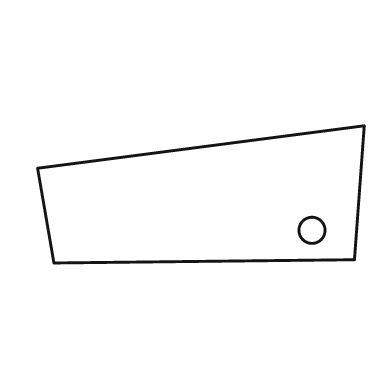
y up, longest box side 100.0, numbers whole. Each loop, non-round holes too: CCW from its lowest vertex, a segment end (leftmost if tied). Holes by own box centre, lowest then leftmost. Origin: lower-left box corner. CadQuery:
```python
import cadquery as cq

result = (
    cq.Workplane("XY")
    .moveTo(5.0, 0.0)
    .lineTo(97.0, 1.0)
    .lineTo(100.0, 42.0)
    .lineTo(0.0, 29.0)
    .close()
    .moveTo(84.0, 10.0)
    .circle(4.0)
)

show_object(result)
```